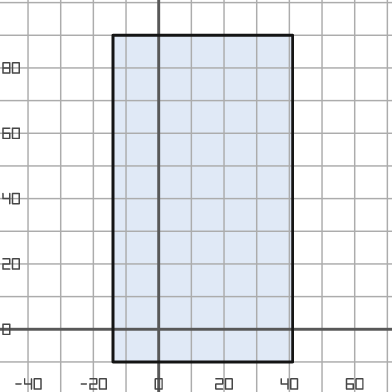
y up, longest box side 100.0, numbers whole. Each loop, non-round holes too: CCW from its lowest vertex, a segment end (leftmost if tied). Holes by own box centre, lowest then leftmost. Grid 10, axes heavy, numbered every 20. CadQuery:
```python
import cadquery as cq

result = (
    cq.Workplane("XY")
    .moveTo(-14.0, -10.0)
    .lineTo(41.0, -10.0)
    .lineTo(41.0, 90.0)
    .lineTo(-14.0, 90.0)
    .close()
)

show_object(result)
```